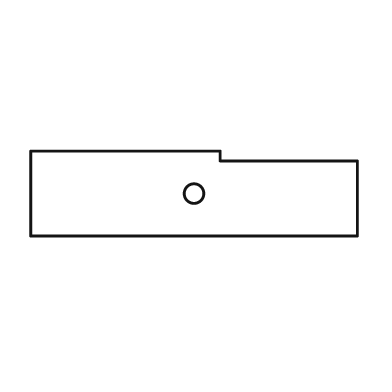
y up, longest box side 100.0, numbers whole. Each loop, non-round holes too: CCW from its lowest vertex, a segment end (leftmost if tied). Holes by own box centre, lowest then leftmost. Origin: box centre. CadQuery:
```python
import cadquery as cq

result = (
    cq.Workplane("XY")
    .moveTo(-50.0, -13.0)
    .lineTo(50.0, -13.0)
    .lineTo(50.0, 10.0)
    .lineTo(8.0, 10.0)
    .lineTo(8.0, 13.0)
    .lineTo(-50.0, 13.0)
    .close()
    .moveTo(0.0, 0.0)
    .circle(3.0)
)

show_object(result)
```